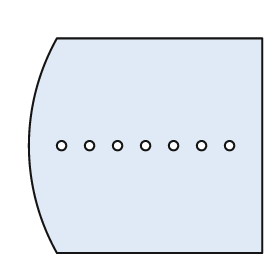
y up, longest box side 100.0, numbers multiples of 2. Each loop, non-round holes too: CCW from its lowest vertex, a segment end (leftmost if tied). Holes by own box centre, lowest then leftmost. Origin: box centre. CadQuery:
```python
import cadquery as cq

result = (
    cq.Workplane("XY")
    .moveTo(-38.0, -46.0)
    .lineTo(50.0, -46.0)
    .lineTo(50.0, 46.0)
    .lineTo(-38.0, 46.0)
    .threePointArc((-50.0, 0.0), (-38.0, -46.0))
    .close()
    .moveTo(-36.0, 0.0)
    .circle(2.0)
    .moveTo(-24.0, 0.0)
    .circle(2.0)
    .moveTo(-12.0, 0.0)
    .circle(2.0)
    .moveTo(0.0, 0.0)
    .circle(2.0)
    .moveTo(12.0, 0.0)
    .circle(2.0)
    .moveTo(24.0, 0.0)
    .circle(2.0)
    .moveTo(36.0, 0.0)
    .circle(2.0)
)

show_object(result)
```